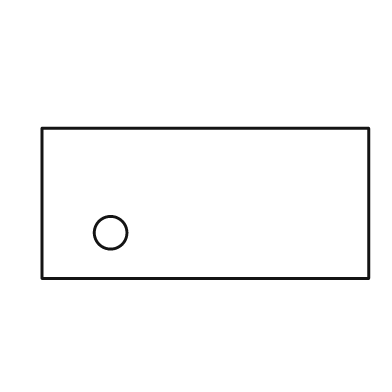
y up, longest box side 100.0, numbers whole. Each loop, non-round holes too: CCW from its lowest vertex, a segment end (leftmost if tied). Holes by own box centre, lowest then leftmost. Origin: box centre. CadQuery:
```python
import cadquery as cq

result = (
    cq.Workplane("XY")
    .moveTo(-50.0, -23.0)
    .lineTo(50.0, -23.0)
    .lineTo(50.0, 23.0)
    .lineTo(-50.0, 23.0)
    .close()
    .moveTo(-29.0, -9.0)
    .circle(5.0)
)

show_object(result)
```